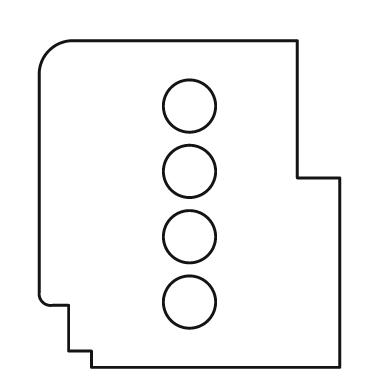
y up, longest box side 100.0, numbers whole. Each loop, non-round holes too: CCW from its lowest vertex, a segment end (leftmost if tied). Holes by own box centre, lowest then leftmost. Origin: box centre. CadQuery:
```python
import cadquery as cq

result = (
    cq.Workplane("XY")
    .moveTo(-30.0, -50.0)
    .lineTo(46.0, -50.0)
    .lineTo(46.0, 8.0)
    .lineTo(33.0, 8.0)
    .lineTo(33.0, 50.0)
    .lineTo(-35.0, 50.0)
    .threePointArc((-43.0, 47.0), (-46.0, 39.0))
    .lineTo(-46.0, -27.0)
    .threePointArc((-45.0, -30.0), (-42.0, -31.0))
    .lineTo(-37.0, -31.0)
    .lineTo(-37.0, -45.0)
    .lineTo(-30.0, -45.0)
    .close()
    .moveTo(0.0, -30.0)
    .circle(8.0)
    .moveTo(0.0, -10.0)
    .circle(8.0)
    .moveTo(0.0, 10.0)
    .circle(8.0)
    .moveTo(0.0, 30.0)
    .circle(8.0)
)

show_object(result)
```